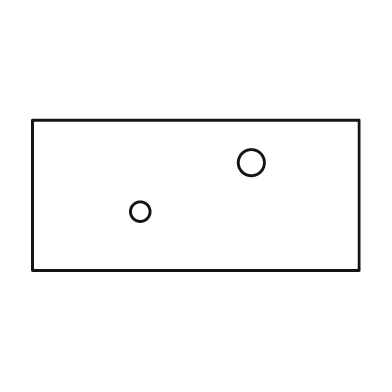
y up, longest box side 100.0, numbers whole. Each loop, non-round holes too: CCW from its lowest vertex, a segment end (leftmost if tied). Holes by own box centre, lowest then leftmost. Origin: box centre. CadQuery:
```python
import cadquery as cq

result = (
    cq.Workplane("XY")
    .moveTo(-50.0, -23.0)
    .lineTo(50.0, -23.0)
    .lineTo(50.0, 23.0)
    .lineTo(-50.0, 23.0)
    .close()
    .moveTo(-17.0, -5.0)
    .circle(3.0)
    .moveTo(17.0, 10.0)
    .circle(4.0)
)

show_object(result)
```